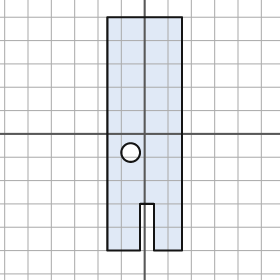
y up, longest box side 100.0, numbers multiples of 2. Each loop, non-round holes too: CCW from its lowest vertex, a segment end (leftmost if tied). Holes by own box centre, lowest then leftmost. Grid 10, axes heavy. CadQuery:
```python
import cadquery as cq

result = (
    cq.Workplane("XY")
    .moveTo(-16.0, -50.0)
    .lineTo(-2.0, -50.0)
    .lineTo(-2.0, -30.0)
    .lineTo(4.0, -30.0)
    .lineTo(4.0, -50.0)
    .lineTo(16.0, -50.0)
    .lineTo(16.0, 50.0)
    .lineTo(-16.0, 50.0)
    .close()
    .moveTo(-6.0, -8.0)
    .circle(4.0)
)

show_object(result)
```